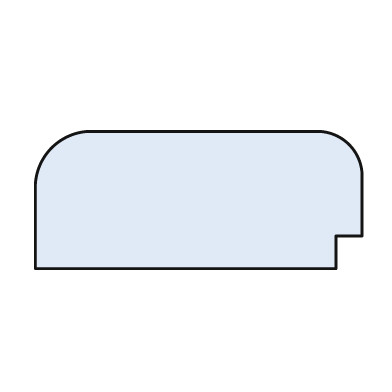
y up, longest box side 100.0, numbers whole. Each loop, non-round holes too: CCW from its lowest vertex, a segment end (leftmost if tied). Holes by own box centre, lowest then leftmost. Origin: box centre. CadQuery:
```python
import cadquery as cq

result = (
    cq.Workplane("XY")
    .moveTo(-50.0, -21.0)
    .lineTo(42.0, -21.0)
    .lineTo(42.0, -11.0)
    .lineTo(50.0, -11.0)
    .lineTo(50.0, 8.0)
    .threePointArc((46.0, 17.0), (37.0, 21.0))
    .lineTo(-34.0, 21.0)
    .threePointArc((-45.0, 16.0), (-50.0, 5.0))
    .close()
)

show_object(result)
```